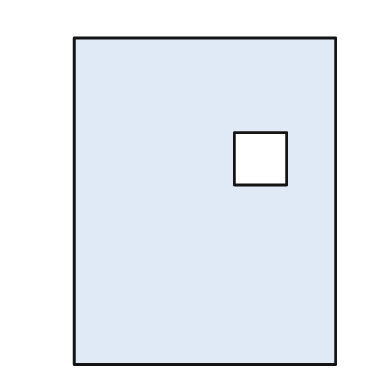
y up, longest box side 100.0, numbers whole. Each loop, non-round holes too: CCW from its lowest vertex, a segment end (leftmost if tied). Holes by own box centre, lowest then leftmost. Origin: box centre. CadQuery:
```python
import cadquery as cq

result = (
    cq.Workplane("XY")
    .moveTo(-40.0, -50.0)
    .lineTo(40.0, -50.0)
    .lineTo(40.0, 50.0)
    .lineTo(-40.0, 50.0)
    .close()
    .moveTo(9.0, 5.0)
    .lineTo(25.0, 5.0)
    .lineTo(25.0, 21.0)
    .lineTo(9.0, 21.0)
    .close()
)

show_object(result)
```